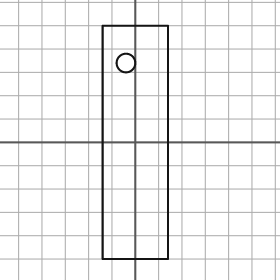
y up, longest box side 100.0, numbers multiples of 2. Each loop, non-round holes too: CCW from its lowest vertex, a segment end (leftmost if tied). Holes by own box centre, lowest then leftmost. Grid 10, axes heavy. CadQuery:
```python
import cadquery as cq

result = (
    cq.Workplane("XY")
    .moveTo(-14.0, -50.0)
    .lineTo(14.0, -50.0)
    .lineTo(14.0, 50.0)
    .lineTo(-14.0, 50.0)
    .close()
    .moveTo(-4.0, 34.0)
    .circle(4.0)
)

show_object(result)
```